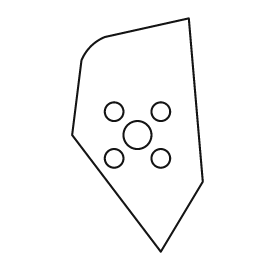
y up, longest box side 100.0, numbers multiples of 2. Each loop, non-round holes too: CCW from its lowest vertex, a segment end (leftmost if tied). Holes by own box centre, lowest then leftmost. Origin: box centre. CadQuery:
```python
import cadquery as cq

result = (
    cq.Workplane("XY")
    .moveTo(10.0, -50.0)
    .lineTo(28.0, -20.0)
    .lineTo(22.0, 50.0)
    .lineTo(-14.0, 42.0)
    .threePointArc((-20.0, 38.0), (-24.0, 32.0))
    .lineTo(-28.0, 0.0)
    .close()
    .moveTo(-10.0, -10.0)
    .circle(4.0)
    .moveTo(10.0, -10.0)
    .circle(4.0)
    .moveTo(0.0, 0.0)
    .circle(6.0)
    .moveTo(-10.0, 10.0)
    .circle(4.0)
    .moveTo(10.0, 10.0)
    .circle(4.0)
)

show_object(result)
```